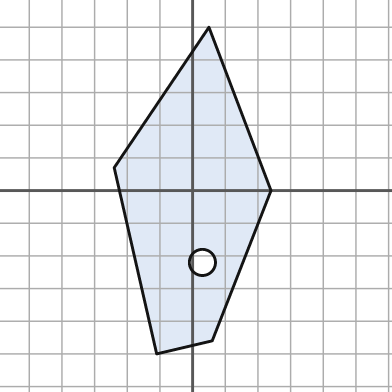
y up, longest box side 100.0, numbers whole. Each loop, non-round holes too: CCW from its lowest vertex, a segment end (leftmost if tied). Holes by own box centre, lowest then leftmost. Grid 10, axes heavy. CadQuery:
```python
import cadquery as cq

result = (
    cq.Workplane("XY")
    .moveTo(-11.0, -50.0)
    .lineTo(6.0, -46.0)
    .lineTo(24.0, 0.0)
    .lineTo(5.0, 50.0)
    .lineTo(-24.0, 7.0)
    .close()
    .moveTo(3.0, -22.0)
    .circle(4.0)
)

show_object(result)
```